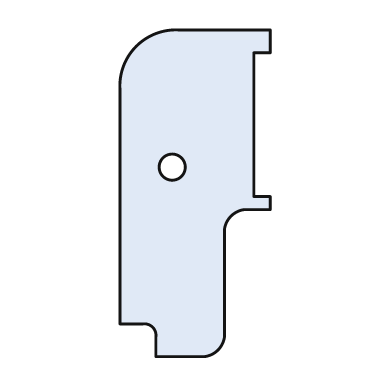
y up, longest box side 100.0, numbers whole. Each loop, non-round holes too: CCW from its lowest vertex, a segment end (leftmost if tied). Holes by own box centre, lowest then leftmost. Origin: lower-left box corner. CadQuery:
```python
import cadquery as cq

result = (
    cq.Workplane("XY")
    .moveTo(11.0, 0.0)
    .lineTo(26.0, 0.0)
    .threePointArc((30.0, 2.0), (32.0, 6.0))
    .lineTo(32.0, 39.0)
    .threePointArc((34.0, 43.0), (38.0, 45.0))
    .lineTo(46.0, 45.0)
    .lineTo(46.0, 49.0)
    .lineTo(41.0, 49.0)
    .lineTo(41.0, 93.0)
    .lineTo(46.0, 93.0)
    .lineTo(46.0, 100.0)
    .lineTo(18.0, 100.0)
    .threePointArc((5.0, 95.0), (0.0, 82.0))
    .lineTo(0.0, 10.0)
    .lineTo(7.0, 10.0)
    .threePointArc((10.0, 9.0), (11.0, 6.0))
    .close()
    .moveTo(16.0, 58.0)
    .circle(4.0)
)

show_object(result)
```